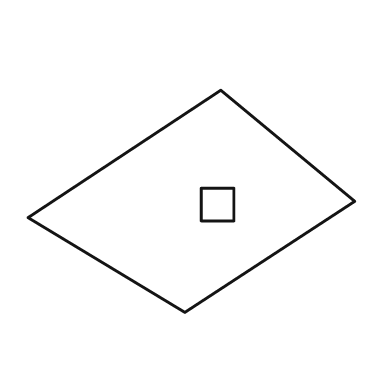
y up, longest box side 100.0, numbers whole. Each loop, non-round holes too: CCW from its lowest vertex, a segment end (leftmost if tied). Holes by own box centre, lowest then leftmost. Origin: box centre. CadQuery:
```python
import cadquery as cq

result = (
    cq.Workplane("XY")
    .moveTo(-2.0, -34.0)
    .lineTo(50.0, 0.0)
    .lineTo(9.0, 34.0)
    .lineTo(-50.0, -5.0)
    .close()
    .moveTo(3.0, -6.0)
    .lineTo(13.0, -6.0)
    .lineTo(13.0, 4.0)
    .lineTo(3.0, 4.0)
    .close()
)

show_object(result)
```